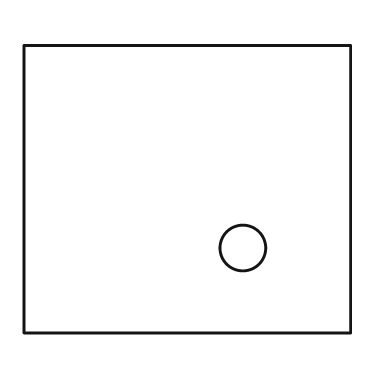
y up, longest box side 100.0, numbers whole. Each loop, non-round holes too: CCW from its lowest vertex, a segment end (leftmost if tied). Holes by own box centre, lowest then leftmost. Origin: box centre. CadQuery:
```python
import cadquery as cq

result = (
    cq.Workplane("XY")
    .moveTo(-50.0, -44.0)
    .lineTo(50.0, -44.0)
    .lineTo(50.0, 44.0)
    .lineTo(-50.0, 44.0)
    .close()
    .moveTo(17.0, -18.0)
    .circle(7.0)
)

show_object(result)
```